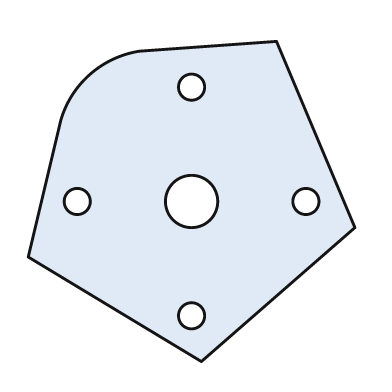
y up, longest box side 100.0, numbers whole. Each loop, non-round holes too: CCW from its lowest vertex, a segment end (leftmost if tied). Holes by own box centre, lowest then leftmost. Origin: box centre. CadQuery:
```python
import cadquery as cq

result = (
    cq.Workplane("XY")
    .moveTo(3.0, -49.0)
    .lineTo(50.0, -8.0)
    .lineTo(26.0, 49.0)
    .lineTo(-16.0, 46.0)
    .threePointArc((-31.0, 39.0), (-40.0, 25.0))
    .lineTo(-50.0, -17.0)
    .close()
    .moveTo(0.0, -35.0)
    .circle(4.0)
    .moveTo(-35.0, 0.0)
    .circle(4.0)
    .moveTo(0.0, 0.0)
    .circle(8.0)
    .moveTo(35.0, 0.0)
    .circle(4.0)
    .moveTo(0.0, 35.0)
    .circle(4.0)
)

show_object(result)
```